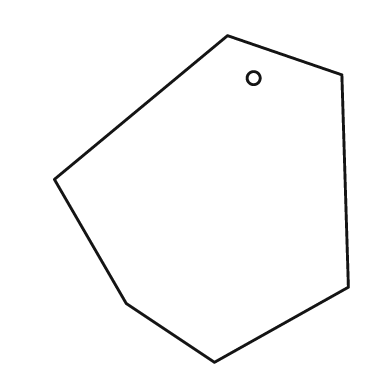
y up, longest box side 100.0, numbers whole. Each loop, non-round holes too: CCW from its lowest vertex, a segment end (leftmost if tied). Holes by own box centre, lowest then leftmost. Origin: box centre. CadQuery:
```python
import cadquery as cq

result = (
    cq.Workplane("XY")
    .moveTo(4.0, -50.0)
    .lineTo(45.0, -27.0)
    .lineTo(43.0, 38.0)
    .lineTo(8.0, 50.0)
    .lineTo(-45.0, 6.0)
    .lineTo(-23.0, -32.0)
    .close()
    .moveTo(16.0, 37.0)
    .circle(2.0)
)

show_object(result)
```